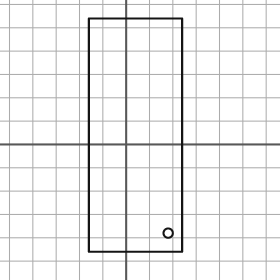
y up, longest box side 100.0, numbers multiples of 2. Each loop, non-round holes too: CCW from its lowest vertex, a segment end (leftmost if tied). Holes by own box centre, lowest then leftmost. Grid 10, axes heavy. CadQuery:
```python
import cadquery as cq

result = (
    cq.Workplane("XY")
    .moveTo(-16.0, -46.0)
    .lineTo(24.0, -46.0)
    .lineTo(24.0, 54.0)
    .lineTo(-16.0, 54.0)
    .close()
    .moveTo(18.0, -38.0)
    .circle(2.0)
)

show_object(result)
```